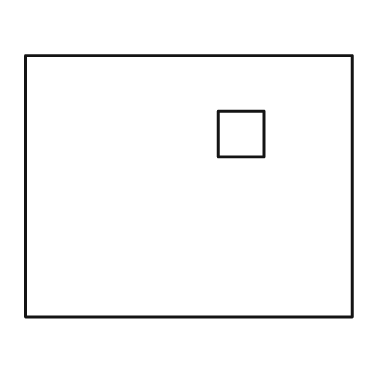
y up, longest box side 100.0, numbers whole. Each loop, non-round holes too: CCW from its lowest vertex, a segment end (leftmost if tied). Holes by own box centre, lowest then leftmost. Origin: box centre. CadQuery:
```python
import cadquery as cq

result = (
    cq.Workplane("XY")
    .moveTo(-50.0, -40.0)
    .lineTo(50.0, -40.0)
    .lineTo(50.0, 40.0)
    .lineTo(-50.0, 40.0)
    .close()
    .moveTo(9.0, 9.0)
    .lineTo(23.0, 9.0)
    .lineTo(23.0, 23.0)
    .lineTo(9.0, 23.0)
    .close()
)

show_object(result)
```